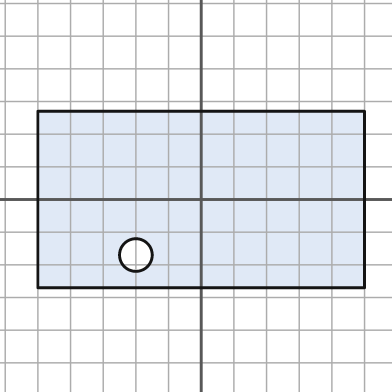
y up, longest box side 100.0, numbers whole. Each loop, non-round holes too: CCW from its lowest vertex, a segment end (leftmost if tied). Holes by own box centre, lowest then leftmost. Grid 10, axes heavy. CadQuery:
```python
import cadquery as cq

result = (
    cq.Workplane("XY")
    .moveTo(-50.0, -27.0)
    .lineTo(50.0, -27.0)
    .lineTo(50.0, 27.0)
    .lineTo(-50.0, 27.0)
    .close()
    .moveTo(-20.0, -17.0)
    .circle(5.0)
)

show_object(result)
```